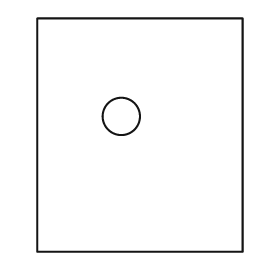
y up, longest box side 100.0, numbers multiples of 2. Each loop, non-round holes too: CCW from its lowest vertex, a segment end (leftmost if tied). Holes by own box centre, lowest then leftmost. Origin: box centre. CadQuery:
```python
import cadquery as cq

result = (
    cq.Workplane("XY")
    .moveTo(-44.0, -50.0)
    .lineTo(44.0, -50.0)
    .lineTo(44.0, 50.0)
    .lineTo(-44.0, 50.0)
    .close()
    .moveTo(-8.0, 8.0)
    .circle(8.0)
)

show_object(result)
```